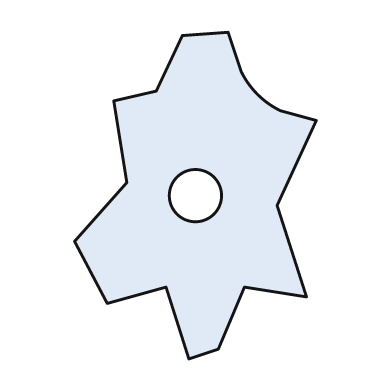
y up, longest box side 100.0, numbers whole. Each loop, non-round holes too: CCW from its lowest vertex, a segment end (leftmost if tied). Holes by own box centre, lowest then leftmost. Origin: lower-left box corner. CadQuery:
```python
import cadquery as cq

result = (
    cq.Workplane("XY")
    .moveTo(35.0, 0.0)
    .lineTo(44.0, 3.0)
    .lineTo(52.0, 22.0)
    .lineTo(71.0, 19.0)
    .lineTo(62.0, 47.0)
    .lineTo(74.0, 73.0)
    .lineTo(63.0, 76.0)
    .threePointArc((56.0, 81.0), (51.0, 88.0))
    .lineTo(47.0, 100.0)
    .lineTo(33.0, 99.0)
    .lineTo(25.0, 82.0)
    .lineTo(12.0, 79.0)
    .lineTo(16.0, 54.0)
    .lineTo(0.0, 36.0)
    .lineTo(10.0, 17.0)
    .lineTo(28.0, 22.0)
    .close()
    .moveTo(37.0, 50.0)
    .circle(8.0)
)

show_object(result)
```